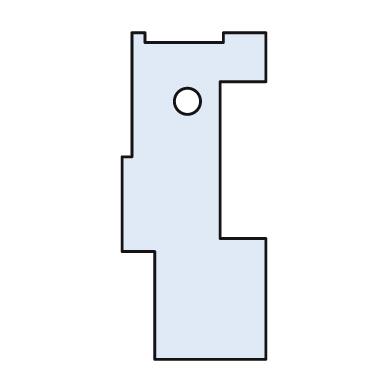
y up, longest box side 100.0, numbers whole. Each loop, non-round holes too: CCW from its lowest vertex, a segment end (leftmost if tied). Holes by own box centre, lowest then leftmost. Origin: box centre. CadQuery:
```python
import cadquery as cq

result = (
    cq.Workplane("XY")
    .moveTo(-12.0, -50.0)
    .lineTo(22.0, -50.0)
    .lineTo(22.0, -13.0)
    .lineTo(8.0, -13.0)
    .lineTo(8.0, 35.0)
    .lineTo(22.0, 35.0)
    .lineTo(22.0, 50.0)
    .lineTo(9.0, 50.0)
    .lineTo(9.0, 47.0)
    .lineTo(-15.0, 47.0)
    .lineTo(-15.0, 50.0)
    .lineTo(-19.0, 50.0)
    .lineTo(-19.0, 12.0)
    .lineTo(-22.0, 12.0)
    .lineTo(-22.0, -17.0)
    .lineTo(-12.0, -17.0)
    .close()
    .moveTo(-2.0, 29.0)
    .circle(4.0)
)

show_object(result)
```